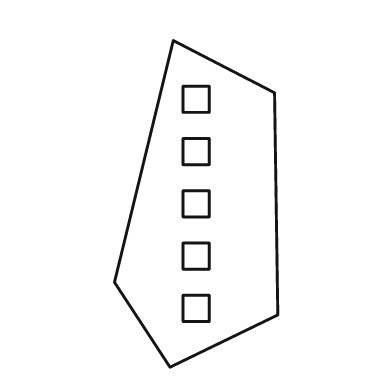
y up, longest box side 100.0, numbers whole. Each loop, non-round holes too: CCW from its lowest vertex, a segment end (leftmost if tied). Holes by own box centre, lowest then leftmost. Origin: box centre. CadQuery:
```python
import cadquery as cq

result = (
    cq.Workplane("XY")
    .moveTo(-8.0, -50.0)
    .lineTo(25.0, -34.0)
    .lineTo(24.0, 34.0)
    .lineTo(-7.0, 50.0)
    .lineTo(-25.0, -24.0)
    .close()
    .moveTo(-4.0, -36.0)
    .lineTo(4.0, -36.0)
    .lineTo(4.0, -28.0)
    .lineTo(-4.0, -28.0)
    .close()
    .moveTo(-4.0, -20.0)
    .lineTo(4.0, -20.0)
    .lineTo(4.0, -12.0)
    .lineTo(-4.0, -12.0)
    .close()
    .moveTo(-4.0, -4.0)
    .lineTo(4.0, -4.0)
    .lineTo(4.0, 4.0)
    .lineTo(-4.0, 4.0)
    .close()
    .moveTo(-4.0, 12.0)
    .lineTo(4.0, 12.0)
    .lineTo(4.0, 20.0)
    .lineTo(-4.0, 20.0)
    .close()
    .moveTo(-4.0, 28.0)
    .lineTo(4.0, 28.0)
    .lineTo(4.0, 36.0)
    .lineTo(-4.0, 36.0)
    .close()
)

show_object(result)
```